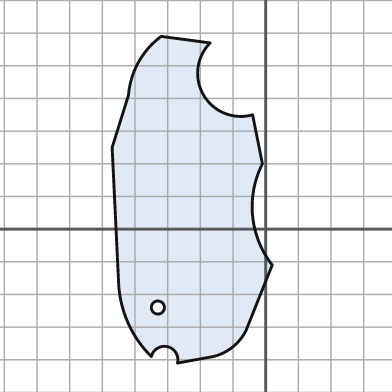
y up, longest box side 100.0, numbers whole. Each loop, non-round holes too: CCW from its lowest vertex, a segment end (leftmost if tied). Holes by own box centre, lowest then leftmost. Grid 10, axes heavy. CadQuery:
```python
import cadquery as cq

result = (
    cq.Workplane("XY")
    .moveTo(-27.0, -41.0)
    .lineTo(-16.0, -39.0)
    .threePointArc((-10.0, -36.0), (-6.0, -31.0))
    .lineTo(2.0, -11.0)
    .threePointArc((-4.0, 4.0), (-1.0, 20.0))
    .lineTo(-4.0, 35.0)
    .threePointArc((-19.0, 41.0), (-17.0, 57.0))
    .lineTo(-32.0, 59.0)
    .threePointArc((-39.0, 51.0), (-42.0, 41.0))
    .lineTo(-47.0, 25.0)
    .lineTo(-45.0, -17.0)
    .threePointArc((-42.0, -29.0), (-35.0, -39.0))
    .threePointArc((-30.0, -36.0), (-27.0, -41.0))
    .close()
    .moveTo(-33.0, -24.0)
    .circle(2.0)
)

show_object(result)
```